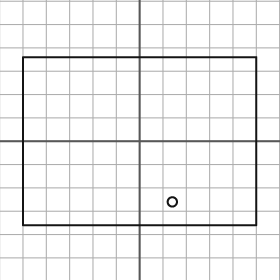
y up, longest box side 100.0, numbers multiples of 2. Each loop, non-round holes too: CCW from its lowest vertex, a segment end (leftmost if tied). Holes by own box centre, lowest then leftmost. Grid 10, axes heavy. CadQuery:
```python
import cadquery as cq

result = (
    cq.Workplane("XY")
    .moveTo(-50.0, -36.0)
    .lineTo(50.0, -36.0)
    .lineTo(50.0, 36.0)
    .lineTo(-50.0, 36.0)
    .close()
    .moveTo(14.0, -26.0)
    .circle(2.0)
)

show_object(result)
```